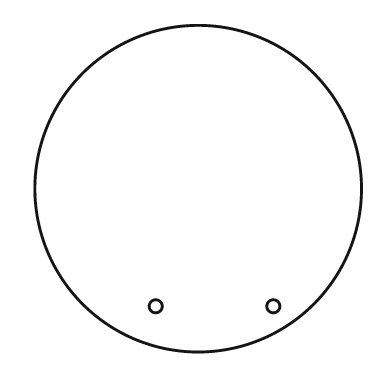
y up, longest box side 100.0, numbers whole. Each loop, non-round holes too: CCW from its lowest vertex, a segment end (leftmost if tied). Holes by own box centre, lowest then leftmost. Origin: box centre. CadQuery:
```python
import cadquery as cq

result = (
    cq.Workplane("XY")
    .moveTo(0.0, 0.0)
    .circle(50.0)
    .moveTo(-13.0, -36.0)
    .circle(2.0)
    .moveTo(23.0, -36.0)
    .circle(2.0)
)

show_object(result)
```